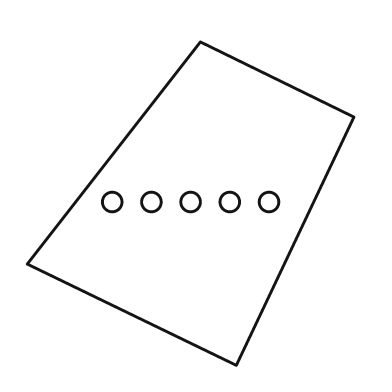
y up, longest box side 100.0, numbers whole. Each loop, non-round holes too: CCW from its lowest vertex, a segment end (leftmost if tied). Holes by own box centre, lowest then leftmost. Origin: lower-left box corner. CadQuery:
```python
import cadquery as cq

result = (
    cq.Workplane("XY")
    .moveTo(64.0, 0.0)
    .lineTo(100.0, 76.0)
    .lineTo(53.0, 99.0)
    .lineTo(0.0, 31.0)
    .close()
    .moveTo(26.0, 50.0)
    .circle(3.0)
    .moveTo(38.0, 50.0)
    .circle(3.0)
    .moveTo(50.0, 50.0)
    .circle(3.0)
    .moveTo(62.0, 50.0)
    .circle(3.0)
    .moveTo(74.0, 50.0)
    .circle(3.0)
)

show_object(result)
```